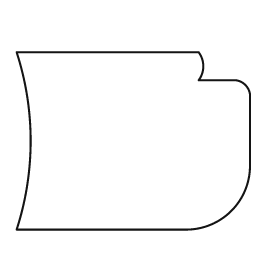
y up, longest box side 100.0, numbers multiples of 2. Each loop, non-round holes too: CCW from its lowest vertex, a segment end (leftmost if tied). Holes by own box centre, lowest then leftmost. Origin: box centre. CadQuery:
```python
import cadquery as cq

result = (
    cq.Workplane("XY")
    .moveTo(-50.0, -38.0)
    .lineTo(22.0, -38.0)
    .threePointArc((42.0, -30.0), (50.0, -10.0))
    .lineTo(50.0, 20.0)
    .threePointArc((48.0, 24.0), (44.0, 26.0))
    .lineTo(28.0, 26.0)
    .threePointArc((30.0, 32.0), (28.0, 38.0))
    .lineTo(-50.0, 38.0)
    .threePointArc((-44.0, 0.0), (-50.0, -38.0))
    .close()
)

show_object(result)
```